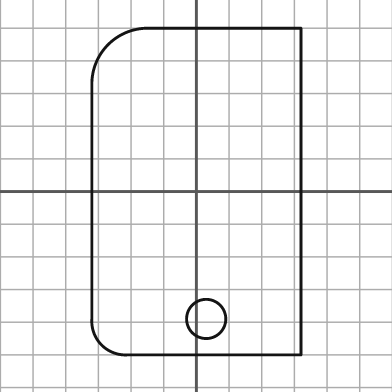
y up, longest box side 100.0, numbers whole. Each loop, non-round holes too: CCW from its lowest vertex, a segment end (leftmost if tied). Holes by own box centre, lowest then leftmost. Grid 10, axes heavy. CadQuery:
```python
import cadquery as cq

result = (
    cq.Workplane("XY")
    .moveTo(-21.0, -50.0)
    .lineTo(32.0, -50.0)
    .lineTo(32.0, 50.0)
    .lineTo(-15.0, 50.0)
    .threePointArc((-27.0, 45.0), (-32.0, 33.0))
    .lineTo(-32.0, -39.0)
    .threePointArc((-29.0, -47.0), (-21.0, -50.0))
    .close()
    .moveTo(3.0, -39.0)
    .circle(6.0)
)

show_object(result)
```